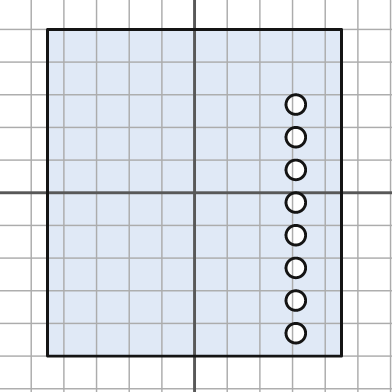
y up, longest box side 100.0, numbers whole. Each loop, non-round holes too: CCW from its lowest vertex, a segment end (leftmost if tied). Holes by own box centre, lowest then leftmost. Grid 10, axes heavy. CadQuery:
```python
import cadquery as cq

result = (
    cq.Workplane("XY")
    .moveTo(-45.0, -50.0)
    .lineTo(45.0, -50.0)
    .lineTo(45.0, 50.0)
    .lineTo(-45.0, 50.0)
    .close()
    .moveTo(31.0, -43.0)
    .circle(3.0)
    .moveTo(31.0, -33.0)
    .circle(3.0)
    .moveTo(31.0, -23.0)
    .circle(3.0)
    .moveTo(31.0, -13.0)
    .circle(3.0)
    .moveTo(31.0, -3.0)
    .circle(3.0)
    .moveTo(31.0, 7.0)
    .circle(3.0)
    .moveTo(31.0, 17.0)
    .circle(3.0)
    .moveTo(31.0, 27.0)
    .circle(3.0)
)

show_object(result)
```